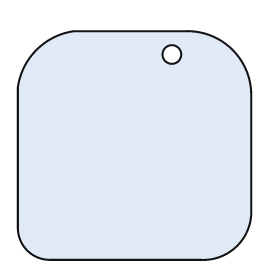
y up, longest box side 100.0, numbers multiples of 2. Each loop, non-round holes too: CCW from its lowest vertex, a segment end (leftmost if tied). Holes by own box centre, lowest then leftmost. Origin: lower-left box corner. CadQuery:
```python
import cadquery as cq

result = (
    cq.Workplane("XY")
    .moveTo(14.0, 0.0)
    .lineTo(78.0, 0.0)
    .threePointArc((94.0, 6.0), (100.0, 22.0))
    .lineTo(100.0, 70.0)
    .threePointArc((92.0, 90.0), (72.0, 98.0))
    .lineTo(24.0, 98.0)
    .threePointArc((8.0, 90.0), (0.0, 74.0))
    .lineTo(0.0, 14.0)
    .threePointArc((4.0, 4.0), (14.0, 0.0))
    .close()
    .moveTo(66.0, 88.0)
    .circle(4.0)
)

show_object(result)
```